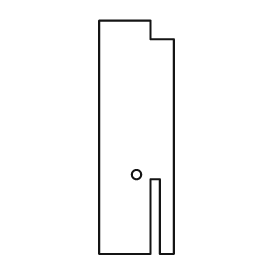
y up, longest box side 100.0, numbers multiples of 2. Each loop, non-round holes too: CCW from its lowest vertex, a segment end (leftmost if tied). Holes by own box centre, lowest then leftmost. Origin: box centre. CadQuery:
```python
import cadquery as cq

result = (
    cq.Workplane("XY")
    .moveTo(-16.0, -50.0)
    .lineTo(6.0, -50.0)
    .lineTo(6.0, -18.0)
    .lineTo(10.0, -18.0)
    .lineTo(10.0, -50.0)
    .lineTo(16.0, -50.0)
    .lineTo(16.0, 42.0)
    .lineTo(6.0, 42.0)
    .lineTo(6.0, 50.0)
    .lineTo(-16.0, 50.0)
    .close()
    .moveTo(0.0, -16.0)
    .circle(2.0)
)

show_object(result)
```